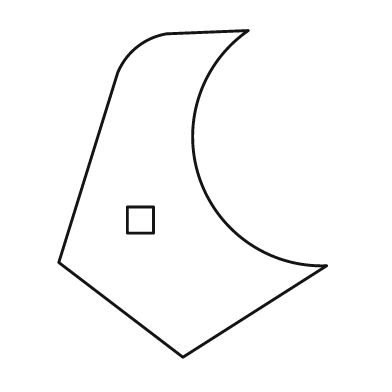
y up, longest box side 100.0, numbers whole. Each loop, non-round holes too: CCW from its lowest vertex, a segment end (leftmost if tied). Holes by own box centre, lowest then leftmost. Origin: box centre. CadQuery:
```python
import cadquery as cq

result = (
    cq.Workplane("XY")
    .moveTo(-3.0, -50.0)
    .lineTo(41.0, -22.0)
    .threePointArc((2.0, 5.0), (17.0, 50.0))
    .lineTo(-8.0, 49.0)
    .threePointArc((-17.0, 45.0), (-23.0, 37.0))
    .lineTo(-41.0, -21.0)
    .close()
    .moveTo(-20.0, -12.0)
    .lineTo(-12.0, -12.0)
    .lineTo(-12.0, -4.0)
    .lineTo(-20.0, -4.0)
    .close()
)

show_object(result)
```